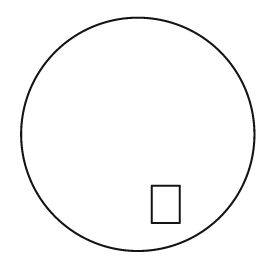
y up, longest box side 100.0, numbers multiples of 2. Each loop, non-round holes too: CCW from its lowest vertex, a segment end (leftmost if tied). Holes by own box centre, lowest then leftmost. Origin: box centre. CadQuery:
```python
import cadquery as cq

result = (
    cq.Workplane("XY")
    .moveTo(0.0, 0.0)
    .circle(50.0)
    .moveTo(6.0, -38.0)
    .lineTo(18.0, -38.0)
    .lineTo(18.0, -22.0)
    .lineTo(6.0, -22.0)
    .close()
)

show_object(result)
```